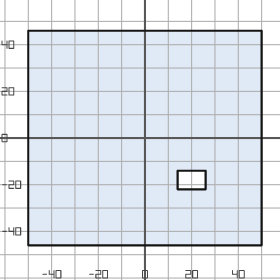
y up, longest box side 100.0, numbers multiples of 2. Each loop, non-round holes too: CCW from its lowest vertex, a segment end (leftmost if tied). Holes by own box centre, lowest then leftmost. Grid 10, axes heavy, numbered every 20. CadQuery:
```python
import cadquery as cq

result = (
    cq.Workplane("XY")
    .moveTo(-50.0, -46.0)
    .lineTo(50.0, -46.0)
    .lineTo(50.0, 46.0)
    .lineTo(-50.0, 46.0)
    .close()
    .moveTo(14.0, -22.0)
    .lineTo(26.0, -22.0)
    .lineTo(26.0, -14.0)
    .lineTo(14.0, -14.0)
    .close()
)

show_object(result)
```